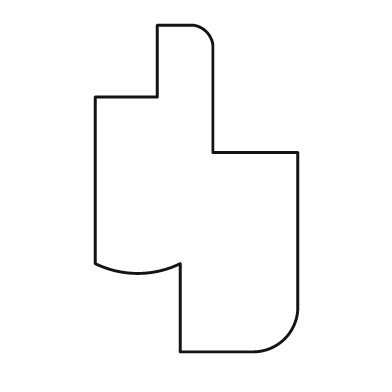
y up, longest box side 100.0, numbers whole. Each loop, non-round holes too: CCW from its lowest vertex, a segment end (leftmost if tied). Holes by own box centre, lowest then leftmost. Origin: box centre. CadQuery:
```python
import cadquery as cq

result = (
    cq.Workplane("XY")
    .moveTo(-5.0, -50.0)
    .lineTo(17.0, -50.0)
    .threePointArc((27.0, -46.0), (31.0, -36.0))
    .lineTo(31.0, 11.0)
    .lineTo(5.0, 11.0)
    .lineTo(5.0, 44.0)
    .threePointArc((3.0, 48.0), (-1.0, 50.0))
    .lineTo(-12.0, 50.0)
    .lineTo(-12.0, 28.0)
    .lineTo(-31.0, 28.0)
    .lineTo(-31.0, -23.0)
    .threePointArc((-18.0, -26.0), (-5.0, -23.0))
    .close()
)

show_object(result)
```